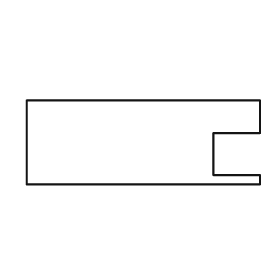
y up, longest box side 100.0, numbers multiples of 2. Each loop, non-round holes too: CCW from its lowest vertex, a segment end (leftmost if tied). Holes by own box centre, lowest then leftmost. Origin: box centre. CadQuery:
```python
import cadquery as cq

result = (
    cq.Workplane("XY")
    .moveTo(-50.0, -18.0)
    .lineTo(50.0, -18.0)
    .lineTo(50.0, -14.0)
    .lineTo(30.0, -14.0)
    .lineTo(30.0, 4.0)
    .lineTo(50.0, 4.0)
    .lineTo(50.0, 18.0)
    .lineTo(-50.0, 18.0)
    .close()
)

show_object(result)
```